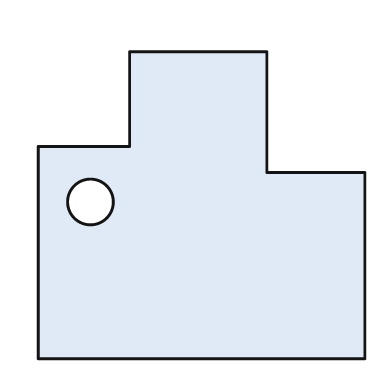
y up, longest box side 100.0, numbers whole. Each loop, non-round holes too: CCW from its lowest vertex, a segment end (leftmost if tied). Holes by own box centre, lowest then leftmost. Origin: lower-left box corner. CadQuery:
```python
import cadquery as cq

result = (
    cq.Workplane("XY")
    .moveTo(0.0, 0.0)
    .lineTo(100.0, 0.0)
    .lineTo(100.0, 57.0)
    .lineTo(70.0, 57.0)
    .lineTo(70.0, 94.0)
    .lineTo(28.0, 94.0)
    .lineTo(28.0, 65.0)
    .lineTo(0.0, 65.0)
    .close()
    .moveTo(16.0, 48.0)
    .circle(7.0)
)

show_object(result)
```